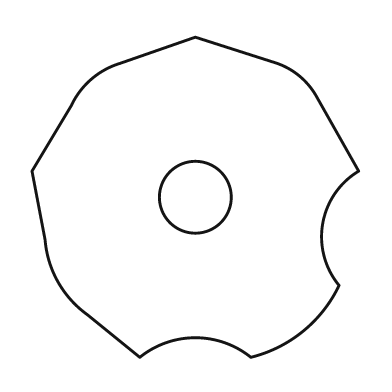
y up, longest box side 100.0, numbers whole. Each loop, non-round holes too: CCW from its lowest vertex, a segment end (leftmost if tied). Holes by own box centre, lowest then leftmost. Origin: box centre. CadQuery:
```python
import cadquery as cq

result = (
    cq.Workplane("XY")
    .moveTo(-17.0, -49.0)
    .threePointArc((0.0, -43.0), (17.0, -49.0))
    .threePointArc((33.0, -41.0), (44.0, -27.0))
    .threePointArc((39.0, -8.0), (50.0, 8.0))
    .lineTo(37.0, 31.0)
    .threePointArc((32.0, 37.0), (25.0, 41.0))
    .lineTo(0.0, 49.0)
    .lineTo(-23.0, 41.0)
    .threePointArc((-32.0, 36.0), (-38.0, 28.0))
    .lineTo(-50.0, 8.0)
    .lineTo(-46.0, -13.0)
    .threePointArc((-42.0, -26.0), (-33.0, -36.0))
    .close()
    .moveTo(0.0, 0.0)
    .circle(11.0)
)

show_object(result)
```